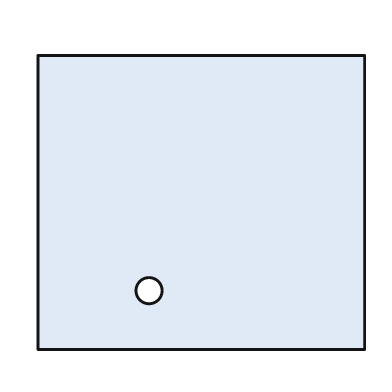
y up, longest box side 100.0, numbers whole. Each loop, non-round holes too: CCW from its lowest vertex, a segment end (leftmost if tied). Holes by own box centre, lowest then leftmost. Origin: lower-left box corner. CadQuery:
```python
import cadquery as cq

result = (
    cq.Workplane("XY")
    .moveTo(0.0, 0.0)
    .lineTo(100.0, 0.0)
    .lineTo(100.0, 90.0)
    .lineTo(0.0, 90.0)
    .close()
    .moveTo(34.0, 18.0)
    .circle(4.0)
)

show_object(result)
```